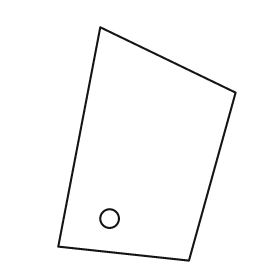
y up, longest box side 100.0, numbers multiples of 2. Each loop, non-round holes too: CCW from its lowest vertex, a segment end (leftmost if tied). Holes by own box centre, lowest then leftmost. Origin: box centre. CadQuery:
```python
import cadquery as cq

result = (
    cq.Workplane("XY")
    .moveTo(18.0, -50.0)
    .lineTo(38.0, 22.0)
    .lineTo(-20.0, 50.0)
    .lineTo(-38.0, -44.0)
    .close()
    .moveTo(-16.0, -32.0)
    .circle(4.0)
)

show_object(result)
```